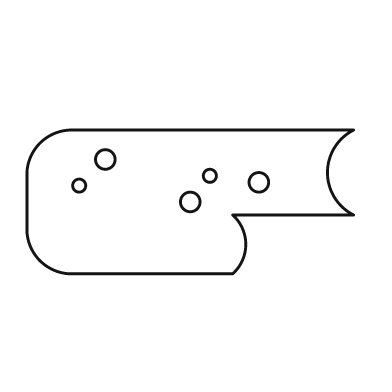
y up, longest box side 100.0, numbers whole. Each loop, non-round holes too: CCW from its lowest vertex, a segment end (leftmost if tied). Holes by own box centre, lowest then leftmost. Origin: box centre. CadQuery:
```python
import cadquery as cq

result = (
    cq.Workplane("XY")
    .moveTo(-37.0, -22.0)
    .lineTo(13.0, -22.0)
    .threePointArc((17.0, -13.0), (13.0, -4.0))
    .lineTo(50.0, -4.0)
    .threePointArc((42.0, 9.0), (50.0, 22.0))
    .lineTo(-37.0, 22.0)
    .threePointArc((-46.0, 18.0), (-50.0, 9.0))
    .lineTo(-50.0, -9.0)
    .threePointArc((-46.0, -18.0), (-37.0, -22.0))
    .close()
    .moveTo(0.0, 0.0)
    .circle(3.0)
    .moveTo(-34.0, 5.0)
    .circle(2.0)
    .moveTo(21.0, 6.0)
    .circle(3.0)
    .moveTo(6.0, 8.0)
    .circle(2.0)
    .moveTo(-26.0, 13.0)
    .circle(3.0)
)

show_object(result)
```